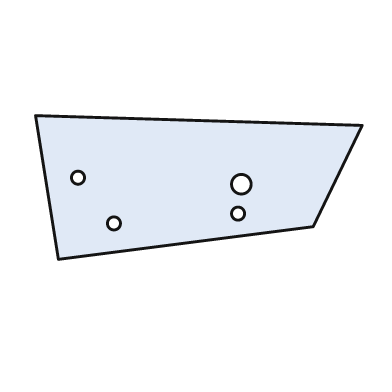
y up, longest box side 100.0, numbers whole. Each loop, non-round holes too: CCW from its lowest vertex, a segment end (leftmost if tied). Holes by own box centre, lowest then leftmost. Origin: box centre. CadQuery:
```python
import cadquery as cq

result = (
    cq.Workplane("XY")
    .moveTo(-43.0, -22.0)
    .lineTo(35.0, -12.0)
    .lineTo(50.0, 19.0)
    .lineTo(-50.0, 22.0)
    .close()
    .moveTo(-26.0, -11.0)
    .circle(2.0)
    .moveTo(12.0, -8.0)
    .circle(2.0)
    .moveTo(13.0, 1.0)
    .circle(3.0)
    .moveTo(-37.0, 3.0)
    .circle(2.0)
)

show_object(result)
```